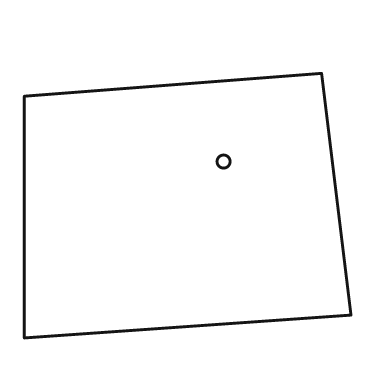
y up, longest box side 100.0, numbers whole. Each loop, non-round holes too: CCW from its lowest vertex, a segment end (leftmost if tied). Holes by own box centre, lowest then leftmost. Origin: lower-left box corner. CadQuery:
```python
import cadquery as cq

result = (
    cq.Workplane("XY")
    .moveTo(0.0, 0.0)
    .lineTo(100.0, 7.0)
    .lineTo(91.0, 81.0)
    .lineTo(0.0, 74.0)
    .close()
    .moveTo(61.0, 54.0)
    .circle(2.0)
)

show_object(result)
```